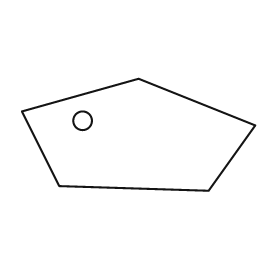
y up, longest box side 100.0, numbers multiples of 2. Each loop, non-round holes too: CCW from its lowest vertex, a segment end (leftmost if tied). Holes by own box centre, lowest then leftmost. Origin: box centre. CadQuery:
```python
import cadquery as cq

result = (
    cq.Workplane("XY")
    .moveTo(30.0, -24.0)
    .lineTo(50.0, 4.0)
    .lineTo(0.0, 24.0)
    .lineTo(-50.0, 10.0)
    .lineTo(-34.0, -22.0)
    .close()
    .moveTo(-24.0, 6.0)
    .circle(4.0)
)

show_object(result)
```